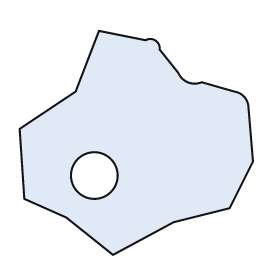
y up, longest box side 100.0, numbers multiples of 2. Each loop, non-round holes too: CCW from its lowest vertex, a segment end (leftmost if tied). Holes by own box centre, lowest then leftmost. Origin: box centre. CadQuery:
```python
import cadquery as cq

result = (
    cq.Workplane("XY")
    .moveTo(-10.0, -48.0)
    .lineTo(16.0, -34.0)
    .lineTo(40.0, -28.0)
    .lineTo(50.0, -8.0)
    .lineTo(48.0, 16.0)
    .threePointArc((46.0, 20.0), (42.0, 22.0))
    .lineTo(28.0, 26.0)
    .threePointArc((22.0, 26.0), (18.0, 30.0))
    .lineTo(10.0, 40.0)
    .threePointArc((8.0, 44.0), (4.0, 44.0))
    .lineTo(-16.0, 48.0)
    .lineTo(-26.0, 22.0)
    .lineTo(-50.0, 6.0)
    .lineTo(-48.0, -24.0)
    .lineTo(-30.0, -32.0)
    .close()
    .moveTo(-18.0, -14.0)
    .circle(10.0)
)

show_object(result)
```